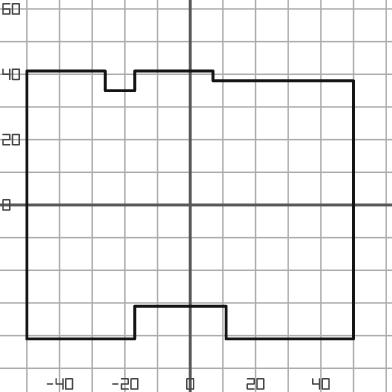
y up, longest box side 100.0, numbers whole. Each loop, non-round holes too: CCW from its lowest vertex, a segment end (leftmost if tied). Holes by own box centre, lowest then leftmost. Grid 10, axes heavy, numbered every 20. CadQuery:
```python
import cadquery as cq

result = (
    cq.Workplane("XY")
    .moveTo(-50.0, -41.0)
    .lineTo(-17.0, -41.0)
    .lineTo(-17.0, -31.0)
    .lineTo(11.0, -31.0)
    .lineTo(11.0, -41.0)
    .lineTo(50.0, -41.0)
    .lineTo(50.0, 38.0)
    .lineTo(7.0, 38.0)
    .lineTo(7.0, 41.0)
    .lineTo(-17.0, 41.0)
    .lineTo(-17.0, 35.0)
    .lineTo(-26.0, 35.0)
    .lineTo(-26.0, 41.0)
    .lineTo(-50.0, 41.0)
    .close()
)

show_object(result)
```